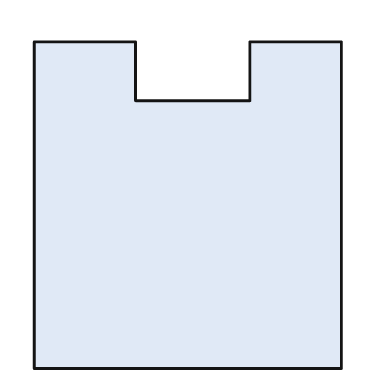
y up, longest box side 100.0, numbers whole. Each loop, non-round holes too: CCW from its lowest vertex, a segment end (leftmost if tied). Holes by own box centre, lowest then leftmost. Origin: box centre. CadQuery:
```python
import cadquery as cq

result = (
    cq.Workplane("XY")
    .moveTo(-47.0, -50.0)
    .lineTo(47.0, -50.0)
    .lineTo(47.0, 50.0)
    .lineTo(19.0, 50.0)
    .lineTo(19.0, 32.0)
    .lineTo(-16.0, 32.0)
    .lineTo(-16.0, 50.0)
    .lineTo(-47.0, 50.0)
    .close()
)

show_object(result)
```